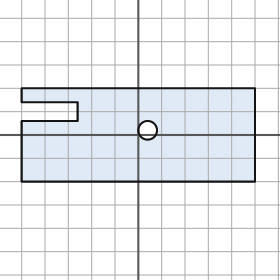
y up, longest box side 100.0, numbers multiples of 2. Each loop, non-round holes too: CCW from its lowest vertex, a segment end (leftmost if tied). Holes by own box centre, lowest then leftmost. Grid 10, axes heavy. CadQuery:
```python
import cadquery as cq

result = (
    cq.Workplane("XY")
    .moveTo(-50.0, -20.0)
    .lineTo(50.0, -20.0)
    .lineTo(50.0, 20.0)
    .lineTo(-50.0, 20.0)
    .lineTo(-50.0, 14.0)
    .lineTo(-26.0, 14.0)
    .lineTo(-26.0, 6.0)
    .lineTo(-50.0, 6.0)
    .close()
    .moveTo(4.0, 2.0)
    .circle(4.0)
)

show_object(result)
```